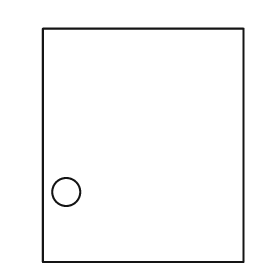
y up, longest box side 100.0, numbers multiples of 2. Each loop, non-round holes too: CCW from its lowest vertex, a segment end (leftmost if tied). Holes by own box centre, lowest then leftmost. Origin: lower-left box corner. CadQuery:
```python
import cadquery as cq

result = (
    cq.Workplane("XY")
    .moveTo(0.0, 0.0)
    .lineTo(86.0, 0.0)
    .lineTo(86.0, 100.0)
    .lineTo(0.0, 100.0)
    .close()
    .moveTo(10.0, 30.0)
    .circle(6.0)
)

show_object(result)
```